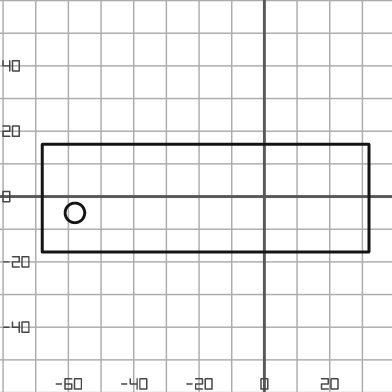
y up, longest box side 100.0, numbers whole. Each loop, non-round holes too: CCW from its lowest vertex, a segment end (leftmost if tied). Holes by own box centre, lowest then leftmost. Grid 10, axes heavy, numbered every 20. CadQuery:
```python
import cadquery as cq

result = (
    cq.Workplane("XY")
    .moveTo(-68.0, -17.0)
    .lineTo(32.0, -17.0)
    .lineTo(32.0, 16.0)
    .lineTo(-68.0, 16.0)
    .close()
    .moveTo(-58.0, -5.0)
    .circle(3.0)
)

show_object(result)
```